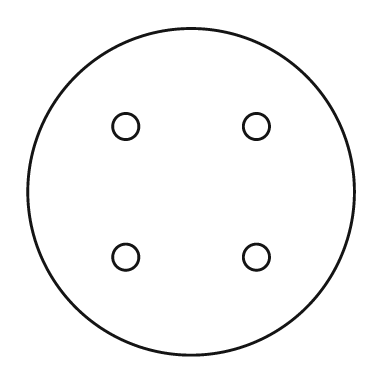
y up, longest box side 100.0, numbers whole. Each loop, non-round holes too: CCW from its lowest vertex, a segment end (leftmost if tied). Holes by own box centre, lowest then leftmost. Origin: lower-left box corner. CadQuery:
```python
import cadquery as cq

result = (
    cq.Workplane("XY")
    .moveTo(50.0, 50.0)
    .circle(50.0)
    .moveTo(30.0, 30.0)
    .circle(4.0)
    .moveTo(70.0, 30.0)
    .circle(4.0)
    .moveTo(30.0, 70.0)
    .circle(4.0)
    .moveTo(70.0, 70.0)
    .circle(4.0)
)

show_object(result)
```